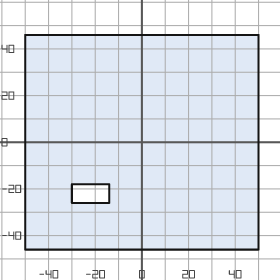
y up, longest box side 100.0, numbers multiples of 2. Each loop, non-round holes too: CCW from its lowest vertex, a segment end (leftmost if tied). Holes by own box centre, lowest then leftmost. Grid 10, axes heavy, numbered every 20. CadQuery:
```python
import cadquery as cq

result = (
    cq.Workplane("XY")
    .moveTo(-50.0, -46.0)
    .lineTo(50.0, -46.0)
    .lineTo(50.0, 46.0)
    .lineTo(-50.0, 46.0)
    .close()
    .moveTo(-30.0, -26.0)
    .lineTo(-14.0, -26.0)
    .lineTo(-14.0, -18.0)
    .lineTo(-30.0, -18.0)
    .close()
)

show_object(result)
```